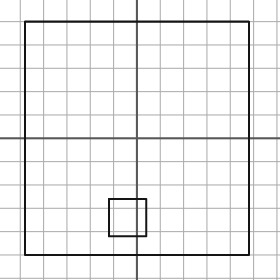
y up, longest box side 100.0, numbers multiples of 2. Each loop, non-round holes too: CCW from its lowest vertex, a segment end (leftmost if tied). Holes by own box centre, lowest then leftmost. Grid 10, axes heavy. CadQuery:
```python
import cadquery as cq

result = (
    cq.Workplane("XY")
    .moveTo(-48.0, -50.0)
    .lineTo(48.0, -50.0)
    .lineTo(48.0, 50.0)
    .lineTo(-48.0, 50.0)
    .close()
    .moveTo(-12.0, -42.0)
    .lineTo(4.0, -42.0)
    .lineTo(4.0, -26.0)
    .lineTo(-12.0, -26.0)
    .close()
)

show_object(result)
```